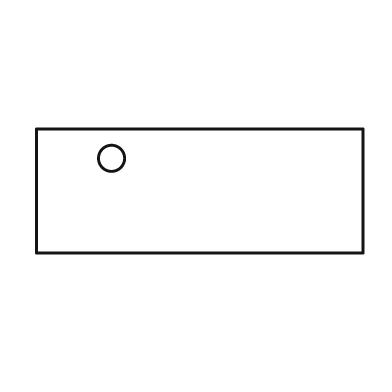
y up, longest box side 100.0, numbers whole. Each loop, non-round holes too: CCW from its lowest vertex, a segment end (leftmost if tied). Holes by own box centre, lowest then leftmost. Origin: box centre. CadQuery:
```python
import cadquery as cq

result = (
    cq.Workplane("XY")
    .moveTo(-50.0, -19.0)
    .lineTo(50.0, -19.0)
    .lineTo(50.0, 19.0)
    .lineTo(-50.0, 19.0)
    .close()
    .moveTo(-27.0, 10.0)
    .circle(4.0)
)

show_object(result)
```